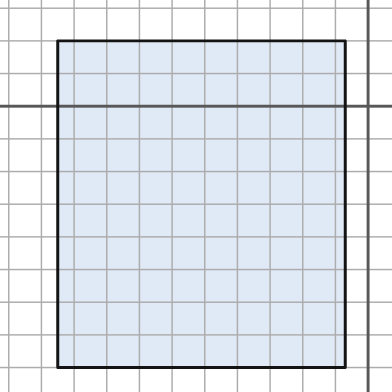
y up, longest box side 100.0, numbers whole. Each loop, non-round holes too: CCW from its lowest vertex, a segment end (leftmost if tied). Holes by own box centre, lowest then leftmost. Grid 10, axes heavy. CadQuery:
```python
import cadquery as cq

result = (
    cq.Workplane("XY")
    .moveTo(-95.0, -80.0)
    .lineTo(-7.0, -80.0)
    .lineTo(-7.0, 20.0)
    .lineTo(-95.0, 20.0)
    .close()
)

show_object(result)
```